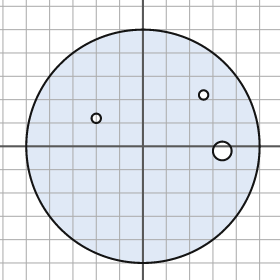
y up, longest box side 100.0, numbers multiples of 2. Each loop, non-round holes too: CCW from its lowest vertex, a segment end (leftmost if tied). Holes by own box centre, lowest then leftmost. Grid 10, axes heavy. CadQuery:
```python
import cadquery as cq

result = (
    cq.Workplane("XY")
    .moveTo(0.0, 0.0)
    .circle(50.0)
    .moveTo(34.0, -2.0)
    .circle(4.0)
    .moveTo(-20.0, 12.0)
    .circle(2.0)
    .moveTo(26.0, 22.0)
    .circle(2.0)
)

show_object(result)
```